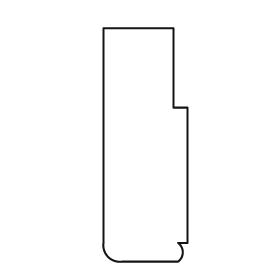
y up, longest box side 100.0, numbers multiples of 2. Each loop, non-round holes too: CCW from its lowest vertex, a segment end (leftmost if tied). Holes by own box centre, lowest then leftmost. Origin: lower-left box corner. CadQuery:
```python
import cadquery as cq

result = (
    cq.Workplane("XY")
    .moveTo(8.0, 0.0)
    .lineTo(32.0, 0.0)
    .threePointArc((34.0, 4.0), (32.0, 8.0))
    .lineTo(36.0, 8.0)
    .lineTo(36.0, 66.0)
    .lineTo(30.0, 66.0)
    .lineTo(30.0, 100.0)
    .lineTo(0.0, 100.0)
    .lineTo(0.0, 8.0)
    .threePointArc((2.0, 2.0), (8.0, 0.0))
    .close()
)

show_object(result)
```